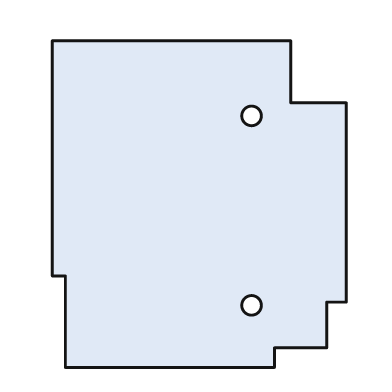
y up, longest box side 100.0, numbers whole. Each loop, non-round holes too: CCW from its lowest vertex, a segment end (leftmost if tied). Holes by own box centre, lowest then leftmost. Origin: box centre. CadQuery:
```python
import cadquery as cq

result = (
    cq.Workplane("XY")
    .moveTo(-41.0, -50.0)
    .lineTo(23.0, -50.0)
    .lineTo(23.0, -44.0)
    .lineTo(39.0, -44.0)
    .lineTo(39.0, -30.0)
    .lineTo(45.0, -30.0)
    .lineTo(45.0, 31.0)
    .lineTo(28.0, 31.0)
    .lineTo(28.0, 50.0)
    .lineTo(-45.0, 50.0)
    .lineTo(-45.0, -22.0)
    .lineTo(-41.0, -22.0)
    .close()
    .moveTo(16.0, -31.0)
    .circle(3.0)
    .moveTo(16.0, 27.0)
    .circle(3.0)
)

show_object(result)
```